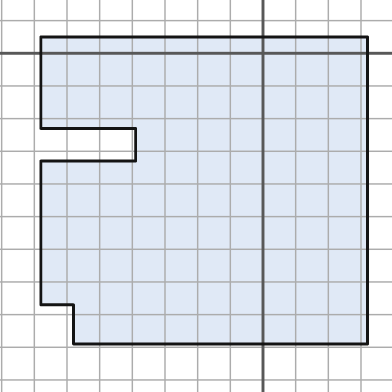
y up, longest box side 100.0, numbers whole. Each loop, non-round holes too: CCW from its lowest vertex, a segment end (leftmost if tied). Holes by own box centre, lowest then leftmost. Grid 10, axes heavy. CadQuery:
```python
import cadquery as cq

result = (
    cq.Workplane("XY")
    .moveTo(-58.0, -89.0)
    .lineTo(32.0, -89.0)
    .lineTo(32.0, 5.0)
    .lineTo(-68.0, 5.0)
    .lineTo(-68.0, -23.0)
    .lineTo(-39.0, -23.0)
    .lineTo(-39.0, -33.0)
    .lineTo(-68.0, -33.0)
    .lineTo(-68.0, -77.0)
    .lineTo(-58.0, -77.0)
    .close()
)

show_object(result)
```